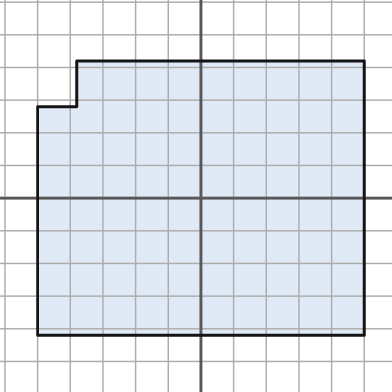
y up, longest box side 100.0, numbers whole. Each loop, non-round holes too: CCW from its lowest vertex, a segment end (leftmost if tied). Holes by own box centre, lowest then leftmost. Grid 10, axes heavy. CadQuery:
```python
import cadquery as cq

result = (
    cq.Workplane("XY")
    .moveTo(-50.0, -42.0)
    .lineTo(50.0, -42.0)
    .lineTo(50.0, 42.0)
    .lineTo(-38.0, 42.0)
    .lineTo(-38.0, 28.0)
    .lineTo(-50.0, 28.0)
    .close()
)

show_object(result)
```